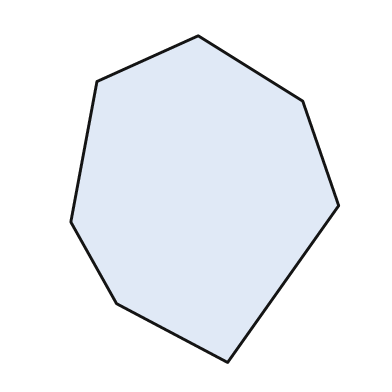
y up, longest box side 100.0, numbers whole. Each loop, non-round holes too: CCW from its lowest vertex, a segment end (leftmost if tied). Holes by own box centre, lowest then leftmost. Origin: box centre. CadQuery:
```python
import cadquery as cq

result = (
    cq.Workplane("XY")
    .moveTo(7.0, -50.0)
    .lineTo(41.0, -2.0)
    .lineTo(30.0, 30.0)
    .lineTo(-2.0, 50.0)
    .lineTo(-33.0, 36.0)
    .lineTo(-41.0, -7.0)
    .lineTo(-27.0, -32.0)
    .close()
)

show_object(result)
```